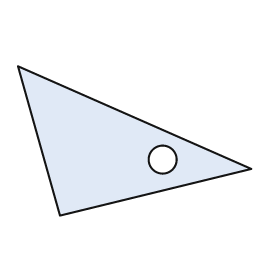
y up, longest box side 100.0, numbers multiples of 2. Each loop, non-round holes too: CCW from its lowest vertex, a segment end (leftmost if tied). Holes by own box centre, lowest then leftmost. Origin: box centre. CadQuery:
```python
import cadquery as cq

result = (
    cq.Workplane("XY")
    .moveTo(-32.0, -32.0)
    .lineTo(50.0, -12.0)
    .lineTo(-50.0, 32.0)
    .close()
    .moveTo(12.0, -8.0)
    .circle(6.0)
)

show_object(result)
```